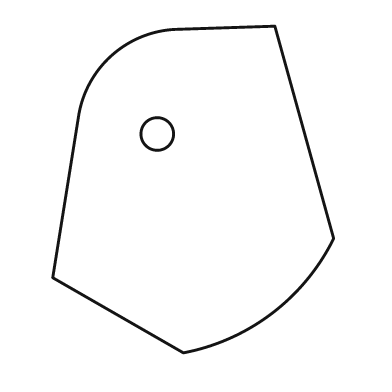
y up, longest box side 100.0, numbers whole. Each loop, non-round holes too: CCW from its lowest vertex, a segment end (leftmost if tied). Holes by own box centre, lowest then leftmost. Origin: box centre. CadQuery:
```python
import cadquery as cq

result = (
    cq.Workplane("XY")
    .moveTo(-3.0, -50.0)
    .threePointArc((24.0, -38.0), (43.0, -15.0))
    .lineTo(25.0, 50.0)
    .lineTo(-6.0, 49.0)
    .threePointArc((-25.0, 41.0), (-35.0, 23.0))
    .lineTo(-43.0, -27.0)
    .close()
    .moveTo(-11.0, 17.0)
    .circle(5.0)
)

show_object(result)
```